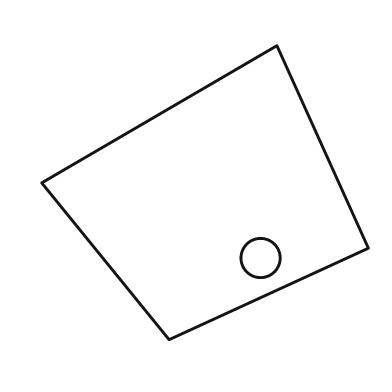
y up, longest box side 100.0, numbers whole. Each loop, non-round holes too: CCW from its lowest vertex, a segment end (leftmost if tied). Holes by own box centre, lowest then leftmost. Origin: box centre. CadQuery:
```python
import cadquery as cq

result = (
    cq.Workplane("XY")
    .moveTo(-11.0, -45.0)
    .lineTo(50.0, -17.0)
    .lineTo(22.0, 45.0)
    .lineTo(-50.0, 3.0)
    .close()
    .moveTo(17.0, -20.0)
    .circle(6.0)
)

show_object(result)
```